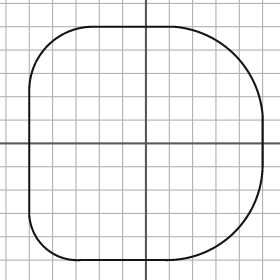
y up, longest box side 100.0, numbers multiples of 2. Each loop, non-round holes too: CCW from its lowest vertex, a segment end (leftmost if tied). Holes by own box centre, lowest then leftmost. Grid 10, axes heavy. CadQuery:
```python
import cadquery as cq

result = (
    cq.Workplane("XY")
    .moveTo(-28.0, -50.0)
    .lineTo(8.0, -50.0)
    .threePointArc((38.0, -38.0), (50.0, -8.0))
    .lineTo(50.0, 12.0)
    .threePointArc((38.0, 38.0), (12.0, 50.0))
    .lineTo(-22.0, 50.0)
    .threePointArc((-42.0, 42.0), (-50.0, 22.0))
    .lineTo(-50.0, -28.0)
    .threePointArc((-44.0, -44.0), (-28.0, -50.0))
    .close()
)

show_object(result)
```